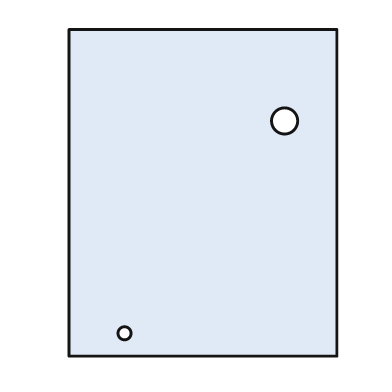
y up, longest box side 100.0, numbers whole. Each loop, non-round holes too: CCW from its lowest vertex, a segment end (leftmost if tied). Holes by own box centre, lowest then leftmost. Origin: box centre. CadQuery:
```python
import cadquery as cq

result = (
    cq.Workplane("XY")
    .moveTo(-41.0, -50.0)
    .lineTo(41.0, -50.0)
    .lineTo(41.0, 50.0)
    .lineTo(-41.0, 50.0)
    .close()
    .moveTo(-24.0, -43.0)
    .circle(2.0)
    .moveTo(25.0, 22.0)
    .circle(4.0)
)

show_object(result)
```